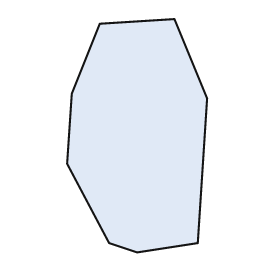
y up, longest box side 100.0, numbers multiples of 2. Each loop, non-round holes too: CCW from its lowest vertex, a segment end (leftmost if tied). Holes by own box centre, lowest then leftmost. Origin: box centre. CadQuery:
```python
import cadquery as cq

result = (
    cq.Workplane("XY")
    .moveTo(0.0, -50.0)
    .lineTo(26.0, -46.0)
    .lineTo(30.0, 16.0)
    .lineTo(16.0, 50.0)
    .lineTo(-16.0, 48.0)
    .lineTo(-28.0, 18.0)
    .lineTo(-30.0, -12.0)
    .lineTo(-12.0, -46.0)
    .close()
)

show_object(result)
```